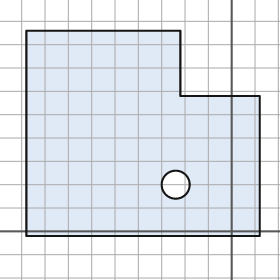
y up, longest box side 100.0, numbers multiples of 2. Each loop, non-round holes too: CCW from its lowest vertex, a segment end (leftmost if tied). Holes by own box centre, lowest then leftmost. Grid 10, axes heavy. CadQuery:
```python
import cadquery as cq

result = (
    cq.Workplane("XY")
    .moveTo(-88.0, -2.0)
    .lineTo(12.0, -2.0)
    .lineTo(12.0, 58.0)
    .lineTo(-22.0, 58.0)
    .lineTo(-22.0, 86.0)
    .lineTo(-88.0, 86.0)
    .close()
    .moveTo(-24.0, 20.0)
    .circle(6.0)
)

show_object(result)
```